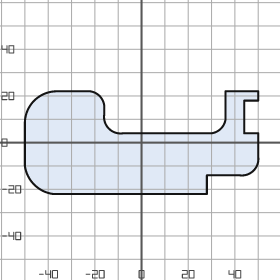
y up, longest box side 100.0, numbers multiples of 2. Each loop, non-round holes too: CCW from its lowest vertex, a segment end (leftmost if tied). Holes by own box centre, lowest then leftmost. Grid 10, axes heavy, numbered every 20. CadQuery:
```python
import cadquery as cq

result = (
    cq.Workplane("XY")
    .moveTo(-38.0, -22.0)
    .lineTo(28.0, -22.0)
    .lineTo(28.0, -14.0)
    .lineTo(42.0, -14.0)
    .threePointArc((48.0, -12.0), (50.0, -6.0))
    .lineTo(50.0, 4.0)
    .lineTo(44.0, 4.0)
    .lineTo(44.0, 18.0)
    .lineTo(50.0, 18.0)
    .lineTo(50.0, 22.0)
    .lineTo(36.0, 22.0)
    .lineTo(36.0, 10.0)
    .threePointArc((34.0, 6.0), (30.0, 4.0))
    .lineTo(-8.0, 4.0)
    .threePointArc((-14.0, 6.0), (-16.0, 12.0))
    .lineTo(-16.0, 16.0)
    .threePointArc((-18.0, 20.0), (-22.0, 22.0))
    .lineTo(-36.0, 22.0)
    .threePointArc((-46.0, 18.0), (-50.0, 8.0))
    .lineTo(-50.0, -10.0)
    .threePointArc((-46.0, -18.0), (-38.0, -22.0))
    .close()
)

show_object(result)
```